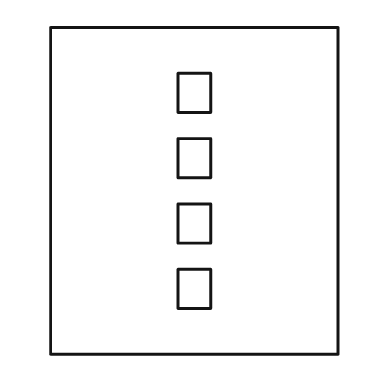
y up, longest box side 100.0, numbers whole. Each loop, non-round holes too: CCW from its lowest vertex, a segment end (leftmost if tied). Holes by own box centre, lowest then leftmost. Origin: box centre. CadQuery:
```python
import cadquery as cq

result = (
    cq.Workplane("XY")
    .moveTo(-44.0, -50.0)
    .lineTo(44.0, -50.0)
    .lineTo(44.0, 50.0)
    .lineTo(-44.0, 50.0)
    .close()
    .moveTo(-5.0, -36.0)
    .lineTo(5.0, -36.0)
    .lineTo(5.0, -24.0)
    .lineTo(-5.0, -24.0)
    .close()
    .moveTo(-5.0, -16.0)
    .lineTo(5.0, -16.0)
    .lineTo(5.0, -4.0)
    .lineTo(-5.0, -4.0)
    .close()
    .moveTo(-5.0, 4.0)
    .lineTo(5.0, 4.0)
    .lineTo(5.0, 16.0)
    .lineTo(-5.0, 16.0)
    .close()
    .moveTo(-5.0, 24.0)
    .lineTo(5.0, 24.0)
    .lineTo(5.0, 36.0)
    .lineTo(-5.0, 36.0)
    .close()
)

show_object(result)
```